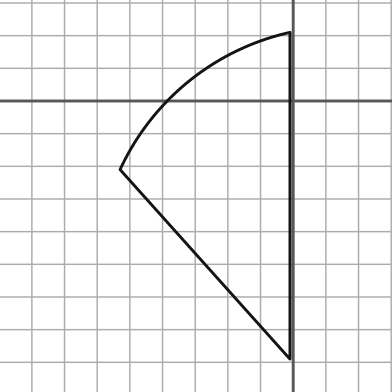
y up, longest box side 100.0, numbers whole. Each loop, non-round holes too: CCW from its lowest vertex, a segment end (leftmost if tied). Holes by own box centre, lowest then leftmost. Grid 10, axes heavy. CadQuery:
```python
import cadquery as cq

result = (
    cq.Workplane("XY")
    .moveTo(-1.0, -79.0)
    .lineTo(-1.0, 21.0)
    .threePointArc((-32.0, 6.0), (-53.0, -21.0))
    .close()
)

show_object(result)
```